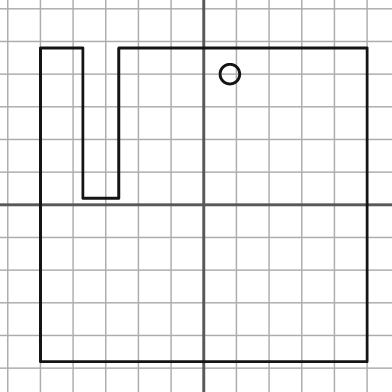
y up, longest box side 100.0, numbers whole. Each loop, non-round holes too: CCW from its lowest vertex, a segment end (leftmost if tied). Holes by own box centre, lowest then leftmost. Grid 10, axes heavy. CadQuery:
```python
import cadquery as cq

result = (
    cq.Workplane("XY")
    .moveTo(-50.0, -48.0)
    .lineTo(50.0, -48.0)
    .lineTo(50.0, 48.0)
    .lineTo(-26.0, 48.0)
    .lineTo(-26.0, 2.0)
    .lineTo(-37.0, 2.0)
    .lineTo(-37.0, 48.0)
    .lineTo(-50.0, 48.0)
    .close()
    .moveTo(8.0, 40.0)
    .circle(3.0)
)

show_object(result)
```